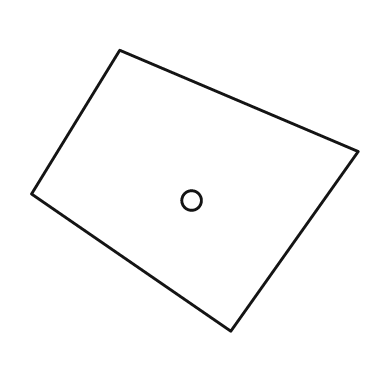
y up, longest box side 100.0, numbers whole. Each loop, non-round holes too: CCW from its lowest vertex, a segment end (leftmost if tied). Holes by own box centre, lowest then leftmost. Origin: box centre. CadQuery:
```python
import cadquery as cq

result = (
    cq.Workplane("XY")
    .moveTo(11.0, -43.0)
    .lineTo(50.0, 12.0)
    .lineTo(-23.0, 43.0)
    .lineTo(-50.0, -1.0)
    .close()
    .moveTo(-1.0, -3.0)
    .circle(3.0)
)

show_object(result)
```